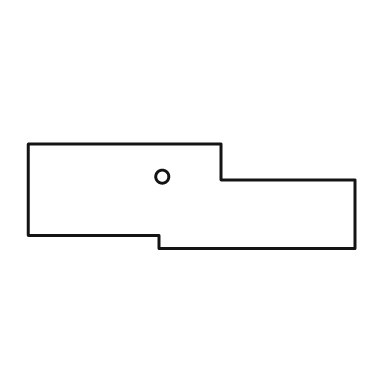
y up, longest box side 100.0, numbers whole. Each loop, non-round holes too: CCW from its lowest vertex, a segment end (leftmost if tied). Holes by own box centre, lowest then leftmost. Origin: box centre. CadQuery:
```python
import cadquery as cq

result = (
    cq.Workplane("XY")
    .moveTo(-10.0, -16.0)
    .lineTo(50.0, -16.0)
    .lineTo(50.0, 5.0)
    .lineTo(9.0, 5.0)
    .lineTo(9.0, 16.0)
    .lineTo(-50.0, 16.0)
    .lineTo(-50.0, -12.0)
    .lineTo(-10.0, -12.0)
    .close()
    .moveTo(-9.0, 6.0)
    .circle(2.0)
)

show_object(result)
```